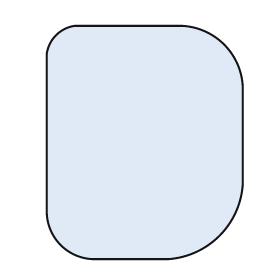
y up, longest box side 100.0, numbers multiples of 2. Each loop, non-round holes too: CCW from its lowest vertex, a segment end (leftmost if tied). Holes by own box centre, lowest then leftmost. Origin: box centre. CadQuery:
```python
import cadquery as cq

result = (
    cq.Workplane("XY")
    .moveTo(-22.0, -50.0)
    .lineTo(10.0, -50.0)
    .threePointArc((32.0, -40.0), (42.0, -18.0))
    .lineTo(42.0, 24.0)
    .threePointArc((34.0, 42.0), (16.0, 50.0))
    .lineTo(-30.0, 50.0)
    .threePointArc((-38.0, 46.0), (-42.0, 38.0))
    .lineTo(-42.0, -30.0)
    .threePointArc((-36.0, -44.0), (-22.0, -50.0))
    .close()
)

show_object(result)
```